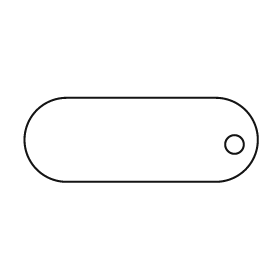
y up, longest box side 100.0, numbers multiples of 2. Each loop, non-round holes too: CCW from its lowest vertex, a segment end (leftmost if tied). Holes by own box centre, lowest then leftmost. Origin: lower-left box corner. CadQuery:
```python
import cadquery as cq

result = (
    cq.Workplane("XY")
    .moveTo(18.0, 0.0)
    .lineTo(82.0, 0.0)
    .threePointArc((100.0, 18.0), (82.0, 36.0))
    .lineTo(18.0, 36.0)
    .threePointArc((0.0, 18.0), (18.0, 0.0))
    .close()
    .moveTo(90.0, 16.0)
    .circle(4.0)
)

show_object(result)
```